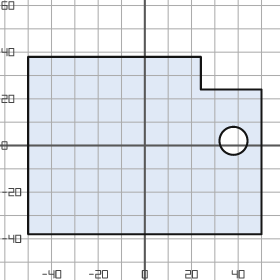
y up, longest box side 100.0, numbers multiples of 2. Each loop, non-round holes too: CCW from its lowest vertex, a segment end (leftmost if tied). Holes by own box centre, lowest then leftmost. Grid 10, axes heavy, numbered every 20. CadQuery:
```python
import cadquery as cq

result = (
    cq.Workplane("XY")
    .moveTo(-50.0, -38.0)
    .lineTo(50.0, -38.0)
    .lineTo(50.0, 24.0)
    .lineTo(24.0, 24.0)
    .lineTo(24.0, 38.0)
    .lineTo(-50.0, 38.0)
    .close()
    .moveTo(38.0, 2.0)
    .circle(6.0)
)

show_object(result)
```